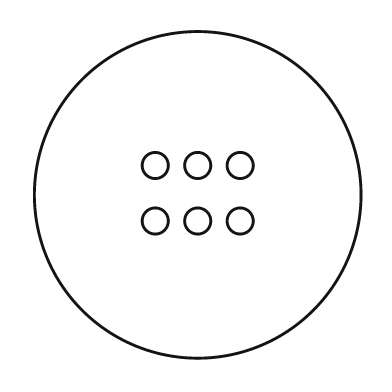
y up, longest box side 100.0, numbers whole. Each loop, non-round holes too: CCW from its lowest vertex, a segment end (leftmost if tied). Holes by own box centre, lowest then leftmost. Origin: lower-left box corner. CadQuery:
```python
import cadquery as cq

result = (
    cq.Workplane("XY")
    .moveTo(50.0, 50.0)
    .circle(50.0)
    .moveTo(37.0, 42.0)
    .circle(4.0)
    .moveTo(50.0, 42.0)
    .circle(4.0)
    .moveTo(63.0, 42.0)
    .circle(4.0)
    .moveTo(37.0, 59.0)
    .circle(4.0)
    .moveTo(50.0, 59.0)
    .circle(4.0)
    .moveTo(63.0, 59.0)
    .circle(4.0)
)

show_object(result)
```